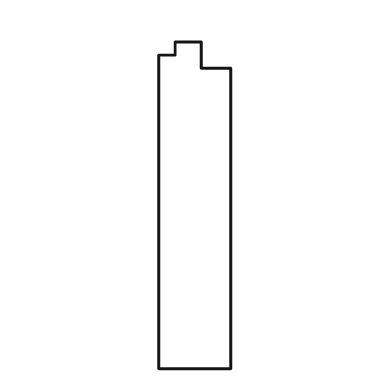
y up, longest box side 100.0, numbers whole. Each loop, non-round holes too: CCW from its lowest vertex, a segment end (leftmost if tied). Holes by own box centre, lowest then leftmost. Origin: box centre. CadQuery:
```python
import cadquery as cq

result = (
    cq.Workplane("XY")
    .moveTo(-11.0, -50.0)
    .lineTo(11.0, -50.0)
    .lineTo(11.0, 42.0)
    .lineTo(2.0, 42.0)
    .lineTo(2.0, 50.0)
    .lineTo(-6.0, 50.0)
    .lineTo(-6.0, 46.0)
    .lineTo(-11.0, 46.0)
    .close()
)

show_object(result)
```